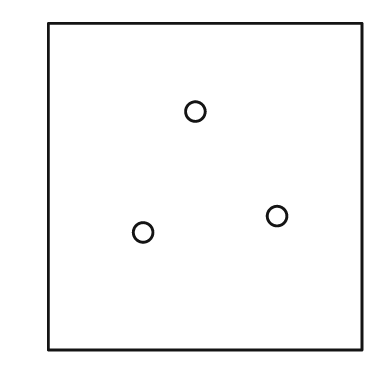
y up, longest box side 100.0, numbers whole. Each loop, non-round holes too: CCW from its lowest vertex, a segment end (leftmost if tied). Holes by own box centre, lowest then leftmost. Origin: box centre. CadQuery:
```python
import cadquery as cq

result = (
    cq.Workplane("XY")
    .moveTo(-48.0, -50.0)
    .lineTo(48.0, -50.0)
    .lineTo(48.0, 50.0)
    .lineTo(-48.0, 50.0)
    .close()
    .moveTo(-19.0, -14.0)
    .circle(3.0)
    .moveTo(22.0, -9.0)
    .circle(3.0)
    .moveTo(-3.0, 23.0)
    .circle(3.0)
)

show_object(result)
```